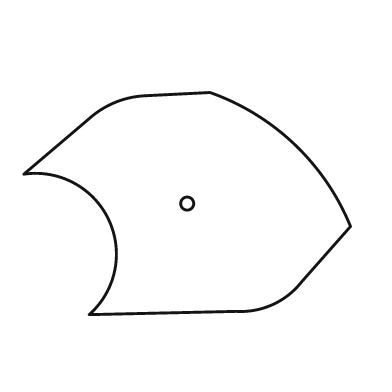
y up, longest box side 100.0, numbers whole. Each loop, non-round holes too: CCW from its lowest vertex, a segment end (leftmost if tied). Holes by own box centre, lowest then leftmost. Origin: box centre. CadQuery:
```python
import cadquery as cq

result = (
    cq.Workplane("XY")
    .moveTo(-30.0, -34.0)
    .lineTo(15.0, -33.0)
    .threePointArc((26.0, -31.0), (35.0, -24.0))
    .lineTo(50.0, -7.0)
    .threePointArc((33.0, 18.0), (7.0, 34.0))
    .lineTo(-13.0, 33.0)
    .threePointArc((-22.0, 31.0), (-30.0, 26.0))
    .lineTo(-50.0, 9.0)
    .threePointArc((-24.0, -5.0), (-30.0, -34.0))
    .close()
    .moveTo(0.0, 0.0)
    .circle(2.0)
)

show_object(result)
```